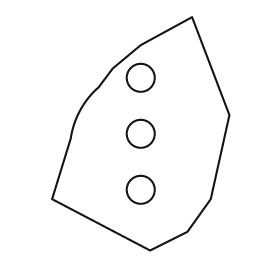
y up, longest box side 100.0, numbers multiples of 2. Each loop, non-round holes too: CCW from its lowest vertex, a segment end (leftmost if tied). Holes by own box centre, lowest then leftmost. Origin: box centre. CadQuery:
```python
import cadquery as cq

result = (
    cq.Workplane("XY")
    .moveTo(4.0, -50.0)
    .lineTo(20.0, -42.0)
    .lineTo(30.0, -28.0)
    .lineTo(38.0, 8.0)
    .lineTo(22.0, 50.0)
    .lineTo(0.0, 38.0)
    .lineTo(-12.0, 28.0)
    .lineTo(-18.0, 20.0)
    .threePointArc((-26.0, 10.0), (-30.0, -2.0))
    .lineTo(-38.0, -28.0)
    .close()
    .moveTo(0.0, -24.0)
    .circle(6.0)
    .moveTo(0.0, 0.0)
    .circle(6.0)
    .moveTo(0.0, 24.0)
    .circle(6.0)
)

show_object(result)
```